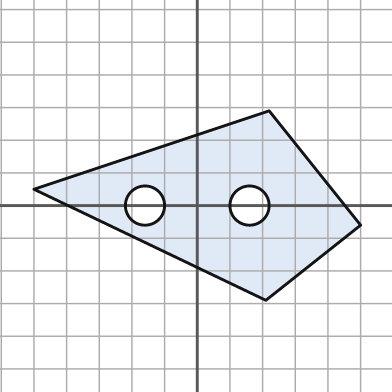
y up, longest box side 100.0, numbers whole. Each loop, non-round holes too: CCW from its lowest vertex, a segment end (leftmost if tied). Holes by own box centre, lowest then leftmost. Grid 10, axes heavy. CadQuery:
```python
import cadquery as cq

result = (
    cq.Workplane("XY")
    .moveTo(21.0, -29.0)
    .lineTo(50.0, -6.0)
    .lineTo(22.0, 29.0)
    .lineTo(-50.0, 5.0)
    .close()
    .moveTo(-16.0, 0.0)
    .circle(6.0)
    .moveTo(16.0, 0.0)
    .circle(6.0)
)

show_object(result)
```